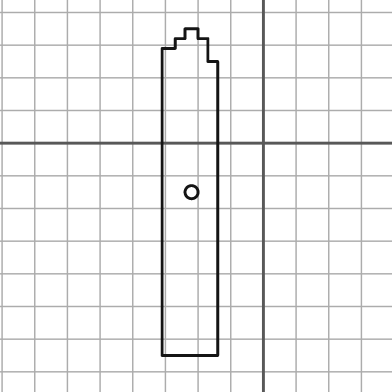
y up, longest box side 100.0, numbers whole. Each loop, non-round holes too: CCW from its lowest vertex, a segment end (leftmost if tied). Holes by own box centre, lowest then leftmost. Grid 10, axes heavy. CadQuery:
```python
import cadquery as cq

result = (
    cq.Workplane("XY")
    .moveTo(-31.0, -65.0)
    .lineTo(-14.0, -65.0)
    .lineTo(-14.0, 25.0)
    .lineTo(-17.0, 25.0)
    .lineTo(-17.0, 32.0)
    .lineTo(-20.0, 32.0)
    .lineTo(-20.0, 35.0)
    .lineTo(-24.0, 35.0)
    .lineTo(-24.0, 32.0)
    .lineTo(-27.0, 32.0)
    .lineTo(-27.0, 29.0)
    .lineTo(-31.0, 29.0)
    .close()
    .moveTo(-22.0, -15.0)
    .circle(2.0)
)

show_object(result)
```